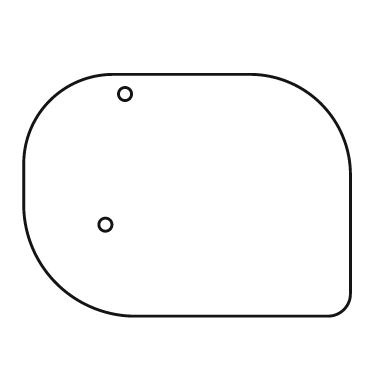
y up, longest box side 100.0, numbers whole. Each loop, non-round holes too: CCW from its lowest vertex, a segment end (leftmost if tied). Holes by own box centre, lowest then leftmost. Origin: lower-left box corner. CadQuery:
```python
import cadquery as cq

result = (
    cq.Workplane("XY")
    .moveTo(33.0, 0.0)
    .lineTo(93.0, 0.0)
    .threePointArc((98.0, 2.0), (100.0, 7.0))
    .lineTo(100.0, 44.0)
    .threePointArc((91.0, 65.0), (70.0, 74.0))
    .lineTo(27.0, 74.0)
    .threePointArc((8.0, 66.0), (0.0, 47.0))
    .lineTo(0.0, 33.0)
    .threePointArc((10.0, 10.0), (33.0, 0.0))
    .close()
    .moveTo(25.0, 28.0)
    .circle(2.0)
    .moveTo(31.0, 68.0)
    .circle(2.0)
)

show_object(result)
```